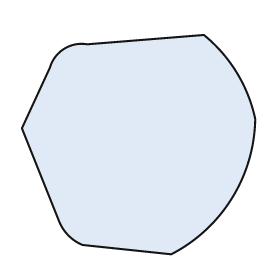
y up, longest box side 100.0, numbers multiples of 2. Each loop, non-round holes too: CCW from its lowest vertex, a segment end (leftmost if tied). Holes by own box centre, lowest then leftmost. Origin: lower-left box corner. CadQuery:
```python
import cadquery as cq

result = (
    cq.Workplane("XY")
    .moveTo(64.0, 0.0)
    .threePointArc((90.0, 24.0), (100.0, 58.0))
    .threePointArc((92.0, 78.0), (78.0, 94.0))
    .lineTo(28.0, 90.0)
    .threePointArc((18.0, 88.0), (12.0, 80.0))
    .lineTo(0.0, 54.0)
    .lineTo(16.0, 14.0)
    .threePointArc((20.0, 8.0), (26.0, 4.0))
    .close()
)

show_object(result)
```